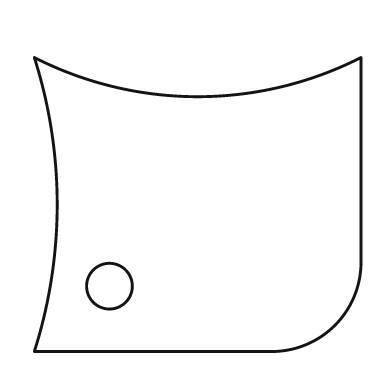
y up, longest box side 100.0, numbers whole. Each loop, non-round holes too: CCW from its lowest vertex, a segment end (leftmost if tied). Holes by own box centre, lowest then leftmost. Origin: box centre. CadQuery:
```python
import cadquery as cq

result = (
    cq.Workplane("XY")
    .moveTo(-50.0, -45.0)
    .lineTo(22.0, -45.0)
    .threePointArc((42.0, -37.0), (50.0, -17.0))
    .lineTo(50.0, 45.0)
    .threePointArc((0.0, 33.0), (-50.0, 45.0))
    .threePointArc((-43.0, 0.0), (-50.0, -45.0))
    .close()
    .moveTo(-27.0, -25.0)
    .circle(7.0)
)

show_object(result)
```